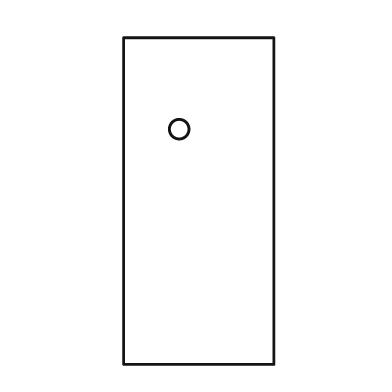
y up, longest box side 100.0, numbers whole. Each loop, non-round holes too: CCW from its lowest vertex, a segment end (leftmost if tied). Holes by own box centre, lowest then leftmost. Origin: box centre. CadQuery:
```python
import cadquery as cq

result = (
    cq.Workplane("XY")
    .moveTo(-23.0, -50.0)
    .lineTo(23.0, -50.0)
    .lineTo(23.0, 50.0)
    .lineTo(-23.0, 50.0)
    .close()
    .moveTo(-6.0, 22.0)
    .circle(3.0)
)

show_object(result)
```